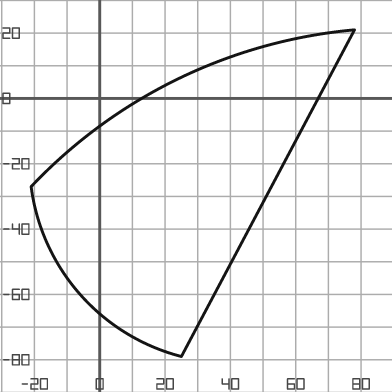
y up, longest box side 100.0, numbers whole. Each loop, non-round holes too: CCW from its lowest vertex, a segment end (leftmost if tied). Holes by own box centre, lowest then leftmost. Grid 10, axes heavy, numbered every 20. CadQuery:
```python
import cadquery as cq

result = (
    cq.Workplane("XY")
    .moveTo(25.0, -79.0)
    .lineTo(78.0, 21.0)
    .threePointArc((24.0, 6.0), (-21.0, -27.0))
    .threePointArc((-6.0, -60.0), (25.0, -79.0))
    .close()
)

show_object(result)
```